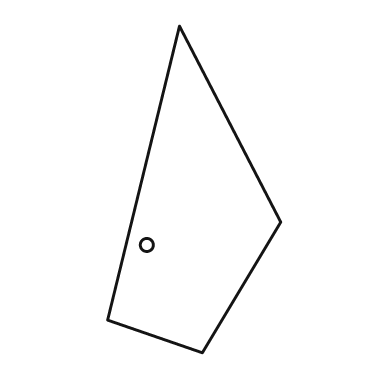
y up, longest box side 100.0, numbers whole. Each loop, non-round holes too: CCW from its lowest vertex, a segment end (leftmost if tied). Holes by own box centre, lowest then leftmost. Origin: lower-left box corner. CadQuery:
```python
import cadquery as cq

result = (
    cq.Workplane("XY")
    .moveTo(29.0, 0.0)
    .lineTo(53.0, 40.0)
    .lineTo(22.0, 100.0)
    .lineTo(0.0, 10.0)
    .close()
    .moveTo(12.0, 33.0)
    .circle(2.0)
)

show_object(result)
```